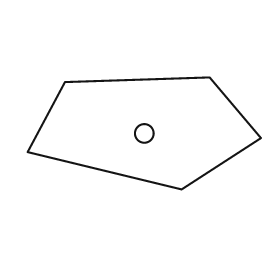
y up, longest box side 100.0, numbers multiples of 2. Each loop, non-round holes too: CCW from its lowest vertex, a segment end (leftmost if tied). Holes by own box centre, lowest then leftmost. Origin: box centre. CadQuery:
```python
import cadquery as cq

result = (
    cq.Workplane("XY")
    .moveTo(16.0, -24.0)
    .lineTo(50.0, -2.0)
    .lineTo(28.0, 24.0)
    .lineTo(-34.0, 22.0)
    .lineTo(-50.0, -8.0)
    .close()
    .moveTo(0.0, 0.0)
    .circle(4.0)
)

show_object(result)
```